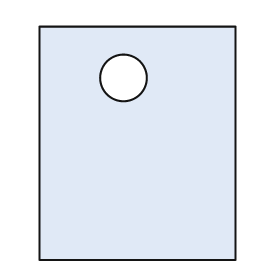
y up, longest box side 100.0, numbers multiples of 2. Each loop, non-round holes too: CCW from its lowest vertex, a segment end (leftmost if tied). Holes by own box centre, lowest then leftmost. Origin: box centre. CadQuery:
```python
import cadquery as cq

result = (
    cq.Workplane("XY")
    .moveTo(-42.0, -50.0)
    .lineTo(42.0, -50.0)
    .lineTo(42.0, 50.0)
    .lineTo(-42.0, 50.0)
    .close()
    .moveTo(-6.0, 28.0)
    .circle(10.0)
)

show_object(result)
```